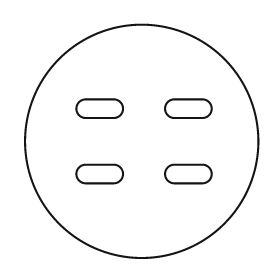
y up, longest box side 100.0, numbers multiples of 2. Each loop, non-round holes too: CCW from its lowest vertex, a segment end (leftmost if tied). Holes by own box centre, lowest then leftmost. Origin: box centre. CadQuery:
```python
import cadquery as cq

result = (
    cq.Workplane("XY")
    .moveTo(0.0, 0.0)
    .circle(50.0)
    .moveTo(-24.0, -18.0)
    .lineTo(-12.0, -18.0)
    .threePointArc((-8.0, -14.0), (-12.0, -10.0))
    .lineTo(-24.0, -10.0)
    .threePointArc((-28.0, -14.0), (-24.0, -18.0))
    .close()
    .moveTo(14.0, -18.0)
    .lineTo(26.0, -18.0)
    .threePointArc((30.0, -14.0), (26.0, -10.0))
    .lineTo(14.0, -10.0)
    .threePointArc((10.0, -14.0), (14.0, -18.0))
    .close()
    .moveTo(-24.0, 10.0)
    .lineTo(-12.0, 10.0)
    .threePointArc((-8.0, 14.0), (-12.0, 18.0))
    .lineTo(-24.0, 18.0)
    .threePointArc((-28.0, 14.0), (-24.0, 10.0))
    .close()
    .moveTo(14.0, 10.0)
    .lineTo(26.0, 10.0)
    .threePointArc((30.0, 14.0), (26.0, 18.0))
    .lineTo(14.0, 18.0)
    .threePointArc((10.0, 14.0), (14.0, 10.0))
    .close()
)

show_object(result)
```